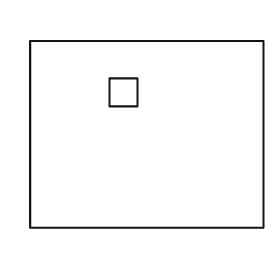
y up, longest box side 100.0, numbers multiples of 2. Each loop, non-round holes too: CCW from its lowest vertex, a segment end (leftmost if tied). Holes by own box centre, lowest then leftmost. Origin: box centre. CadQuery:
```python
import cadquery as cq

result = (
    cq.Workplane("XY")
    .moveTo(-50.0, -40.0)
    .lineTo(50.0, -40.0)
    .lineTo(50.0, 40.0)
    .lineTo(-50.0, 40.0)
    .close()
    .moveTo(-16.0, 12.0)
    .lineTo(-4.0, 12.0)
    .lineTo(-4.0, 24.0)
    .lineTo(-16.0, 24.0)
    .close()
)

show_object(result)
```